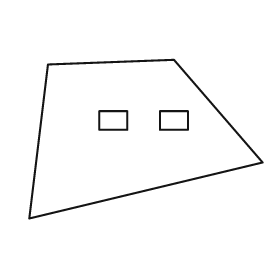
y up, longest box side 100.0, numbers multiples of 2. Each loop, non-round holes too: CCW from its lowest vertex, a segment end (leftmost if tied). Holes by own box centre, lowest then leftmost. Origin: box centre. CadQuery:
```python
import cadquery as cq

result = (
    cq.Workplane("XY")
    .moveTo(-50.0, -34.0)
    .lineTo(50.0, -10.0)
    .lineTo(12.0, 34.0)
    .lineTo(-42.0, 32.0)
    .close()
    .moveTo(-20.0, 4.0)
    .lineTo(-8.0, 4.0)
    .lineTo(-8.0, 12.0)
    .lineTo(-20.0, 12.0)
    .close()
    .moveTo(6.0, 4.0)
    .lineTo(18.0, 4.0)
    .lineTo(18.0, 12.0)
    .lineTo(6.0, 12.0)
    .close()
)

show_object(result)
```